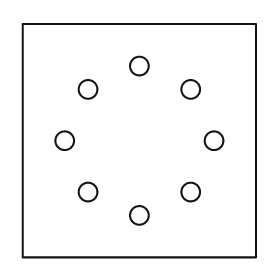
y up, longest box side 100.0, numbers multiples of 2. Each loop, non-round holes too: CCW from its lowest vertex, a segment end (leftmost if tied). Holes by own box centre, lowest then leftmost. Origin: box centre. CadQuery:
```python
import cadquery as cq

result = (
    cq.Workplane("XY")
    .moveTo(-50.0, -50.0)
    .lineTo(50.0, -50.0)
    .lineTo(50.0, 50.0)
    .lineTo(-50.0, 50.0)
    .close()
    .moveTo(0.0, -32.0)
    .circle(4.0)
    .moveTo(-22.0, -22.0)
    .circle(4.0)
    .moveTo(22.0, -22.0)
    .circle(4.0)
    .moveTo(-32.0, 0.0)
    .circle(4.0)
    .moveTo(32.0, 0.0)
    .circle(4.0)
    .moveTo(-22.0, 22.0)
    .circle(4.0)
    .moveTo(22.0, 22.0)
    .circle(4.0)
    .moveTo(0.0, 32.0)
    .circle(4.0)
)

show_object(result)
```